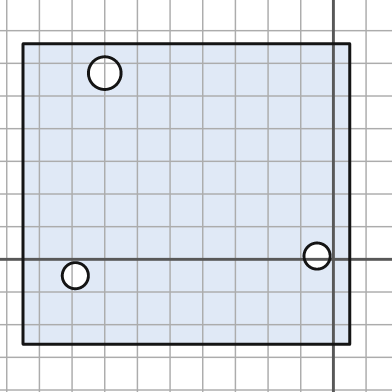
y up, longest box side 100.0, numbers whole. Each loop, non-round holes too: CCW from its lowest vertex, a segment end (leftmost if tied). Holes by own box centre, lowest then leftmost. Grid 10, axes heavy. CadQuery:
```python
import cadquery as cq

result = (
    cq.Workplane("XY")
    .moveTo(-95.0, -26.0)
    .lineTo(5.0, -26.0)
    .lineTo(5.0, 66.0)
    .lineTo(-95.0, 66.0)
    .close()
    .moveTo(-79.0, -5.0)
    .circle(4.0)
    .moveTo(-5.0, 1.0)
    .circle(4.0)
    .moveTo(-70.0, 57.0)
    .circle(5.0)
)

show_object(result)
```